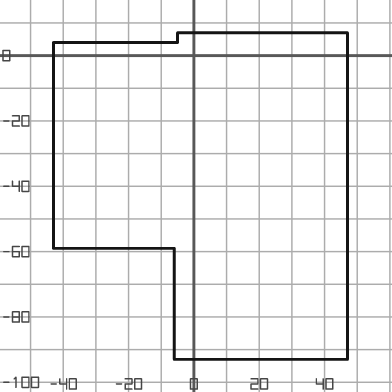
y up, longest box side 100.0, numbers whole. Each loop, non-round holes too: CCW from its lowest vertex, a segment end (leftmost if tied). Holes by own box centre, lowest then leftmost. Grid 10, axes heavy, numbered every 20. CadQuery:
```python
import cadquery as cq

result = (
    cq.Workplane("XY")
    .moveTo(-6.0, -93.0)
    .lineTo(47.0, -93.0)
    .lineTo(47.0, 7.0)
    .lineTo(-5.0, 7.0)
    .lineTo(-5.0, 4.0)
    .lineTo(-43.0, 4.0)
    .lineTo(-43.0, -59.0)
    .lineTo(-6.0, -59.0)
    .close()
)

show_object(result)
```